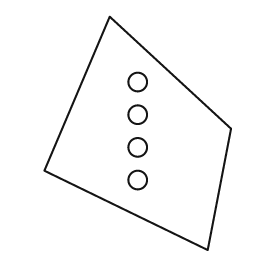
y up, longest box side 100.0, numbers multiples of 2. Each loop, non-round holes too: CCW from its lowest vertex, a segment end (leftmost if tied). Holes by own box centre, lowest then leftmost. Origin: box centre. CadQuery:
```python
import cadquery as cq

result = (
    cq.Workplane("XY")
    .moveTo(30.0, -50.0)
    .lineTo(40.0, 2.0)
    .lineTo(-12.0, 50.0)
    .lineTo(-40.0, -16.0)
    .close()
    .moveTo(0.0, -20.0)
    .circle(4.0)
    .moveTo(0.0, -6.0)
    .circle(4.0)
    .moveTo(0.0, 8.0)
    .circle(4.0)
    .moveTo(0.0, 22.0)
    .circle(4.0)
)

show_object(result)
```